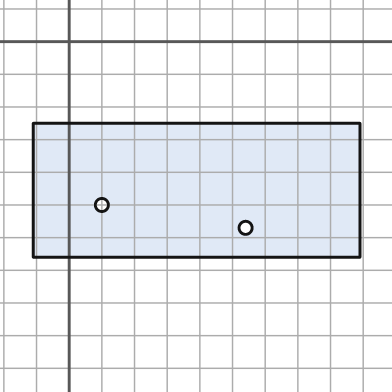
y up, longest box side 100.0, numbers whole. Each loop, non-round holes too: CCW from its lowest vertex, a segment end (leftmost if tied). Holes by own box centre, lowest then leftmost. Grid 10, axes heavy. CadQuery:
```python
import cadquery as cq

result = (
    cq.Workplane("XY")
    .moveTo(-11.0, -66.0)
    .lineTo(89.0, -66.0)
    .lineTo(89.0, -25.0)
    .lineTo(-11.0, -25.0)
    .close()
    .moveTo(54.0, -57.0)
    .circle(2.0)
    .moveTo(10.0, -50.0)
    .circle(2.0)
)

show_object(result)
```